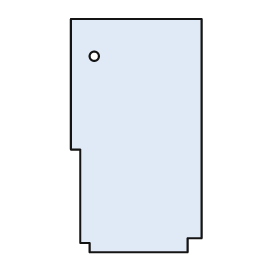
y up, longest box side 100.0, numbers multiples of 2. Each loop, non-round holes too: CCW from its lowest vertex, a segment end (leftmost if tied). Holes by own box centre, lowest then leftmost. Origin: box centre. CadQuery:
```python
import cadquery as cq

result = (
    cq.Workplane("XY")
    .moveTo(-20.0, -50.0)
    .lineTo(22.0, -50.0)
    .lineTo(22.0, -44.0)
    .lineTo(28.0, -44.0)
    .lineTo(28.0, 50.0)
    .lineTo(-28.0, 50.0)
    .lineTo(-28.0, -6.0)
    .lineTo(-24.0, -6.0)
    .lineTo(-24.0, -46.0)
    .lineTo(-20.0, -46.0)
    .close()
    .moveTo(-18.0, 34.0)
    .circle(2.0)
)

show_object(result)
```